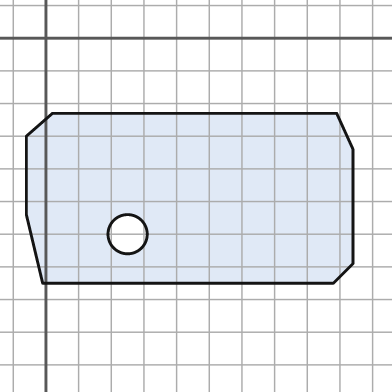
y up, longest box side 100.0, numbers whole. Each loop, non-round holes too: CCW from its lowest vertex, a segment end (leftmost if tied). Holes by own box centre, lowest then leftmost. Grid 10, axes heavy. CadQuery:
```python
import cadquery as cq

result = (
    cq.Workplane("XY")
    .moveTo(-1.0, -75.0)
    .lineTo(88.0, -75.0)
    .lineTo(94.0, -69.0)
    .lineTo(94.0, -34.0)
    .lineTo(89.0, -23.0)
    .lineTo(2.0, -23.0)
    .lineTo(-6.0, -30.0)
    .lineTo(-6.0, -54.0)
    .close()
    .moveTo(25.0, -60.0)
    .circle(6.0)
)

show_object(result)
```